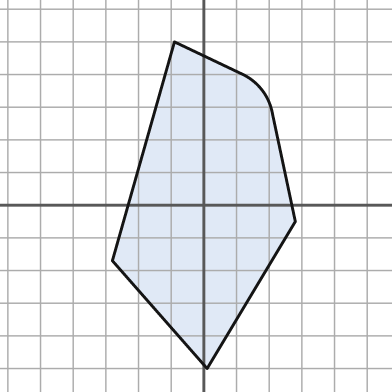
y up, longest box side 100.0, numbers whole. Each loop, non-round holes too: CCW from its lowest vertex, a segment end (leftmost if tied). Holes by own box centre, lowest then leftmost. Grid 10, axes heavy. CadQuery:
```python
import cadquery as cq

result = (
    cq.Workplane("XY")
    .moveTo(1.0, -50.0)
    .lineTo(28.0, -5.0)
    .lineTo(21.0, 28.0)
    .threePointArc((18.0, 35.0), (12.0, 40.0))
    .lineTo(-9.0, 50.0)
    .lineTo(-28.0, -17.0)
    .close()
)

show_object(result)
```